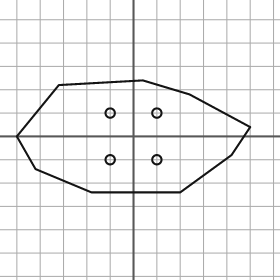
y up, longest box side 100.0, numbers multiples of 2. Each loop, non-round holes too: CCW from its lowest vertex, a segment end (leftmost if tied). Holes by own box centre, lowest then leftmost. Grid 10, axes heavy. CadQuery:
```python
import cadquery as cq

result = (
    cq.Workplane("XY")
    .moveTo(-18.0, -24.0)
    .lineTo(20.0, -24.0)
    .lineTo(42.0, -8.0)
    .lineTo(50.0, 4.0)
    .lineTo(24.0, 18.0)
    .lineTo(4.0, 24.0)
    .lineTo(-32.0, 22.0)
    .lineTo(-50.0, 0.0)
    .lineTo(-42.0, -14.0)
    .close()
    .moveTo(-10.0, -10.0)
    .circle(2.0)
    .moveTo(10.0, -10.0)
    .circle(2.0)
    .moveTo(-10.0, 10.0)
    .circle(2.0)
    .moveTo(10.0, 10.0)
    .circle(2.0)
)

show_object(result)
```